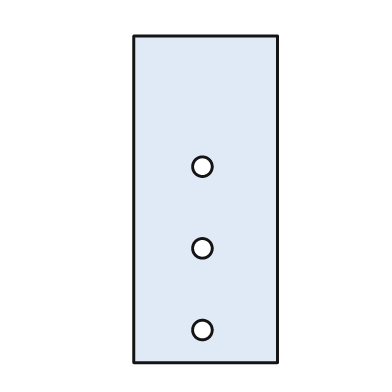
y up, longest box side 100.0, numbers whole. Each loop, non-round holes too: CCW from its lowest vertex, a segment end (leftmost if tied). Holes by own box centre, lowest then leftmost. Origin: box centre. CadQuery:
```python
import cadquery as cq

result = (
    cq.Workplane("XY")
    .moveTo(-22.0, -50.0)
    .lineTo(22.0, -50.0)
    .lineTo(22.0, 50.0)
    .lineTo(-22.0, 50.0)
    .close()
    .moveTo(-1.0, -40.0)
    .circle(3.0)
    .moveTo(-1.0, -15.0)
    .circle(3.0)
    .moveTo(-1.0, 10.0)
    .circle(3.0)
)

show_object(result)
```